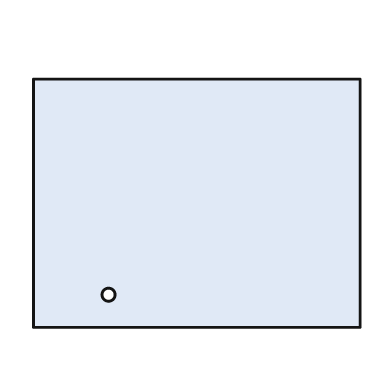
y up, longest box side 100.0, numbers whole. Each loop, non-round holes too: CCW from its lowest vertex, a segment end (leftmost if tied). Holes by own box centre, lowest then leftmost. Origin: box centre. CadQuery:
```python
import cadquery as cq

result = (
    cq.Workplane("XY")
    .moveTo(-50.0, -38.0)
    .lineTo(50.0, -38.0)
    .lineTo(50.0, 38.0)
    .lineTo(-50.0, 38.0)
    .close()
    .moveTo(-27.0, -28.0)
    .circle(2.0)
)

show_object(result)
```